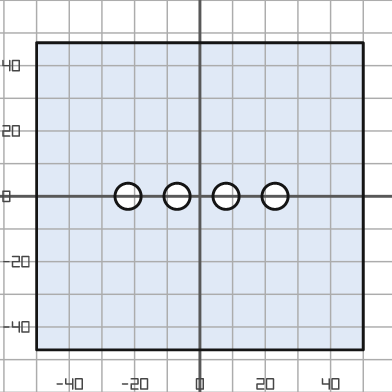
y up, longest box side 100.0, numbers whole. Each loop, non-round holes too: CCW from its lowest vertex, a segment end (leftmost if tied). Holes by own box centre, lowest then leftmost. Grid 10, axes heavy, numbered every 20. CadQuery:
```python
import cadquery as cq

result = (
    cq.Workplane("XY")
    .moveTo(-50.0, -47.0)
    .lineTo(50.0, -47.0)
    .lineTo(50.0, 47.0)
    .lineTo(-50.0, 47.0)
    .close()
    .moveTo(-22.0, 0.0)
    .circle(4.0)
    .moveTo(-7.0, 0.0)
    .circle(4.0)
    .moveTo(8.0, 0.0)
    .circle(4.0)
    .moveTo(23.0, 0.0)
    .circle(4.0)
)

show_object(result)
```